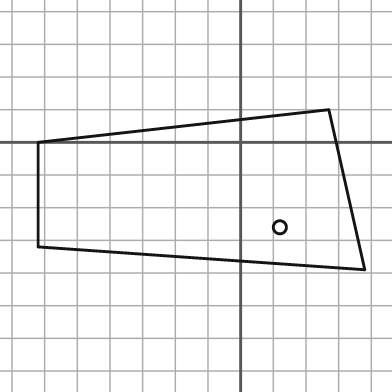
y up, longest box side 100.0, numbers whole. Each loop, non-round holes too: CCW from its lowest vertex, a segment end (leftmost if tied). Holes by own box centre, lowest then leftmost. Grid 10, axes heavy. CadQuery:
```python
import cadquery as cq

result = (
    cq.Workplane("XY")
    .moveTo(38.0, -39.0)
    .lineTo(27.0, 10.0)
    .lineTo(-62.0, 0.0)
    .lineTo(-62.0, -32.0)
    .close()
    .moveTo(12.0, -26.0)
    .circle(2.0)
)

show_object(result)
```